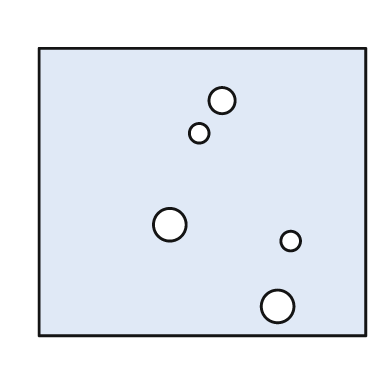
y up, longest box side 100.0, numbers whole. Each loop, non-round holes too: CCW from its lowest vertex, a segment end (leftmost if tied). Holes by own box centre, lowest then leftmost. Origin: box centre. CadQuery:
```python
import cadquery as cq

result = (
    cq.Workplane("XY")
    .moveTo(-50.0, -44.0)
    .lineTo(50.0, -44.0)
    .lineTo(50.0, 44.0)
    .lineTo(-50.0, 44.0)
    .close()
    .moveTo(23.0, -35.0)
    .circle(5.0)
    .moveTo(27.0, -15.0)
    .circle(3.0)
    .moveTo(-10.0, -10.0)
    .circle(5.0)
    .moveTo(-1.0, 18.0)
    .circle(3.0)
    .moveTo(6.0, 28.0)
    .circle(4.0)
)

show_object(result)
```